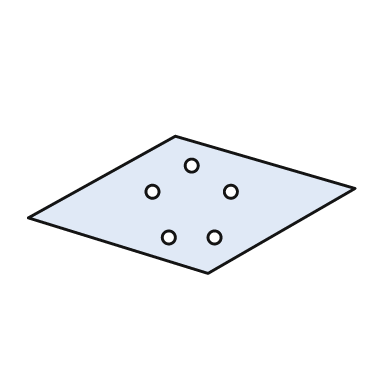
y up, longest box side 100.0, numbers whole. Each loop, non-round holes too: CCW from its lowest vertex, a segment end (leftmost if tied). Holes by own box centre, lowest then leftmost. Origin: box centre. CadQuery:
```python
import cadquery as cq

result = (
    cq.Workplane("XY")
    .moveTo(5.0, -21.0)
    .lineTo(50.0, 5.0)
    .lineTo(-5.0, 21.0)
    .lineTo(-50.0, -4.0)
    .close()
    .moveTo(-7.0, -10.0)
    .circle(2.0)
    .moveTo(7.0, -10.0)
    .circle(2.0)
    .moveTo(-12.0, 4.0)
    .circle(2.0)
    .moveTo(12.0, 4.0)
    .circle(2.0)
    .moveTo(0.0, 12.0)
    .circle(2.0)
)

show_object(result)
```